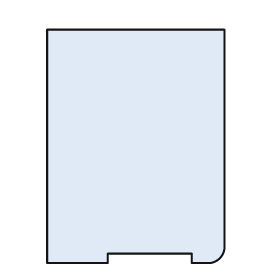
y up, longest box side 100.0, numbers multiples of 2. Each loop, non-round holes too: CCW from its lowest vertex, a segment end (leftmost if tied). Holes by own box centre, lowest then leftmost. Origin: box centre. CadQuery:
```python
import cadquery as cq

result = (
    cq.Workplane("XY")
    .moveTo(-38.0, -50.0)
    .lineTo(-12.0, -50.0)
    .lineTo(-12.0, -46.0)
    .lineTo(24.0, -46.0)
    .lineTo(24.0, -50.0)
    .lineTo(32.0, -50.0)
    .threePointArc((36.0, -48.0), (38.0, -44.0))
    .lineTo(38.0, 50.0)
    .lineTo(-38.0, 50.0)
    .close()
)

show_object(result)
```